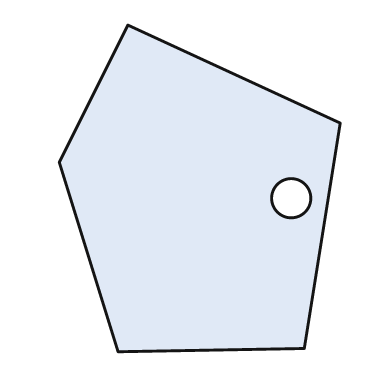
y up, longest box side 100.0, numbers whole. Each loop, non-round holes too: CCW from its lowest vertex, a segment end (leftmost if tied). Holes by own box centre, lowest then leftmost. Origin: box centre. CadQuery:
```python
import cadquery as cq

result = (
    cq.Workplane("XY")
    .moveTo(-25.0, -50.0)
    .lineTo(32.0, -49.0)
    .lineTo(43.0, 20.0)
    .lineTo(-22.0, 50.0)
    .lineTo(-43.0, 8.0)
    .close()
    .moveTo(28.0, -3.0)
    .circle(6.0)
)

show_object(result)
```